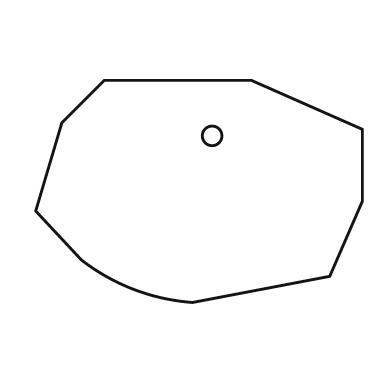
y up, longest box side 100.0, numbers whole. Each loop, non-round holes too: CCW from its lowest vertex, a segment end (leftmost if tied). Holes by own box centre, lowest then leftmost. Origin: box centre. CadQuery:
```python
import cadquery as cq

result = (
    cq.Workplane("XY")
    .moveTo(-2.0, -34.0)
    .lineTo(40.0, -26.0)
    .lineTo(50.0, -3.0)
    .lineTo(50.0, 19.0)
    .lineTo(16.0, 34.0)
    .lineTo(-29.0, 34.0)
    .lineTo(-42.0, 21.0)
    .lineTo(-50.0, -6.0)
    .lineTo(-36.0, -21.0)
    .threePointArc((-20.0, -30.0), (-2.0, -34.0))
    .close()
    .moveTo(4.0, 17.0)
    .circle(3.0)
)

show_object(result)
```